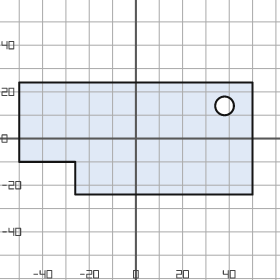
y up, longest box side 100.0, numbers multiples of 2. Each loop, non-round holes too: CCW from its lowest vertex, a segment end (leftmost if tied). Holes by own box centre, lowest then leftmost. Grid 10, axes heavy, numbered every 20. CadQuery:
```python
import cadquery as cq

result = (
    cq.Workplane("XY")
    .moveTo(-26.0, -24.0)
    .lineTo(50.0, -24.0)
    .lineTo(50.0, 24.0)
    .lineTo(-50.0, 24.0)
    .lineTo(-50.0, -10.0)
    .lineTo(-26.0, -10.0)
    .close()
    .moveTo(38.0, 14.0)
    .circle(4.0)
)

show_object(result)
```